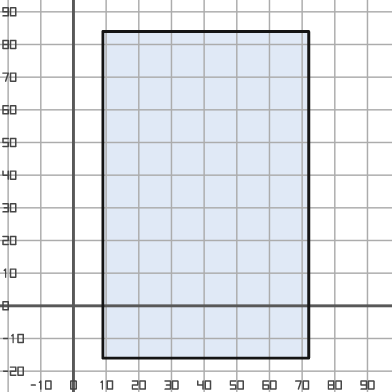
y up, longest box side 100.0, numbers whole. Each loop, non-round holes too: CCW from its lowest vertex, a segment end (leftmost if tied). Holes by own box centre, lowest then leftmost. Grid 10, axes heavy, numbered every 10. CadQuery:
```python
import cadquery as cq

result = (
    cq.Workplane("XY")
    .moveTo(9.0, -16.0)
    .lineTo(72.0, -16.0)
    .lineTo(72.0, 84.0)
    .lineTo(9.0, 84.0)
    .close()
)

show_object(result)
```